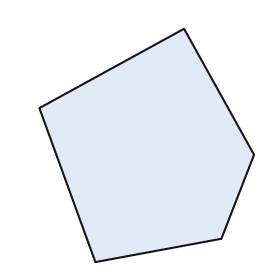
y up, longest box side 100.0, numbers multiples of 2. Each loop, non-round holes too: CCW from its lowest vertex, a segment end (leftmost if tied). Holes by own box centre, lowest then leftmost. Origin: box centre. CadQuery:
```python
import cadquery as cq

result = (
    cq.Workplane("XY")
    .moveTo(-22.0, -50.0)
    .lineTo(32.0, -40.0)
    .lineTo(46.0, -4.0)
    .lineTo(16.0, 50.0)
    .lineTo(-46.0, 16.0)
    .close()
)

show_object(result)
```